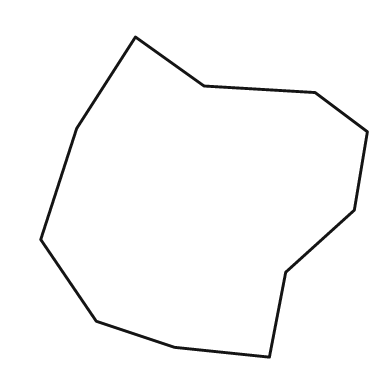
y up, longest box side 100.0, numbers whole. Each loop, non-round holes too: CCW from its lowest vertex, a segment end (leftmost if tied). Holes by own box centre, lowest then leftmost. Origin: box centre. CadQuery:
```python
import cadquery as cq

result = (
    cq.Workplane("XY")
    .moveTo(20.0, -49.0)
    .lineTo(25.0, -23.0)
    .lineTo(46.0, -4.0)
    .lineTo(50.0, 20.0)
    .lineTo(34.0, 32.0)
    .lineTo(0.0, 34.0)
    .lineTo(-21.0, 49.0)
    .lineTo(-39.0, 21.0)
    .lineTo(-50.0, -13.0)
    .lineTo(-33.0, -38.0)
    .lineTo(-9.0, -46.0)
    .close()
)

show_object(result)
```